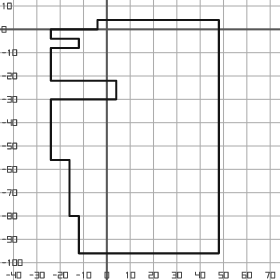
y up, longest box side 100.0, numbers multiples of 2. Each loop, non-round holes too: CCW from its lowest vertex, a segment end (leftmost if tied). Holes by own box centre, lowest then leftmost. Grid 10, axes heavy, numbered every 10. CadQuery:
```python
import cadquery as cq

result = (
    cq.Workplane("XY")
    .moveTo(-12.0, -96.0)
    .lineTo(48.0, -96.0)
    .lineTo(48.0, 4.0)
    .lineTo(-4.0, 4.0)
    .lineTo(-4.0, 0.0)
    .lineTo(-24.0, 0.0)
    .lineTo(-24.0, -4.0)
    .lineTo(-12.0, -4.0)
    .lineTo(-12.0, -8.0)
    .lineTo(-24.0, -8.0)
    .lineTo(-24.0, -22.0)
    .lineTo(4.0, -22.0)
    .lineTo(4.0, -30.0)
    .lineTo(-24.0, -30.0)
    .lineTo(-24.0, -56.0)
    .lineTo(-16.0, -56.0)
    .lineTo(-16.0, -80.0)
    .lineTo(-12.0, -80.0)
    .close()
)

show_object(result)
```